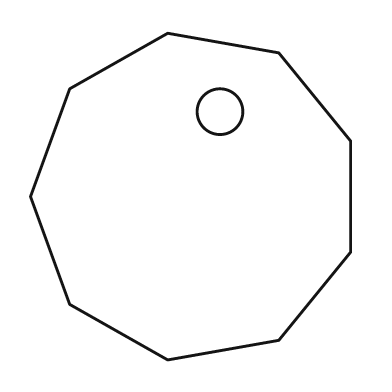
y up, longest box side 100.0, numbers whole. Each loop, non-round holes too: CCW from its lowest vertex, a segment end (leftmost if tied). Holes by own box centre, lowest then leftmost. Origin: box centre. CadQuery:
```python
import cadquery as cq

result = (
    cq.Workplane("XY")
    .moveTo(-7.0, -50.0)
    .lineTo(27.0, -44.0)
    .lineTo(49.0, -17.0)
    .lineTo(49.0, 17.0)
    .lineTo(27.0, 44.0)
    .lineTo(-7.0, 50.0)
    .lineTo(-37.0, 33.0)
    .lineTo(-49.0, 0.0)
    .lineTo(-37.0, -33.0)
    .close()
    .moveTo(9.0, 26.0)
    .circle(7.0)
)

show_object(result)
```